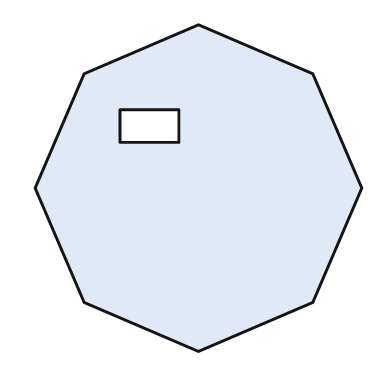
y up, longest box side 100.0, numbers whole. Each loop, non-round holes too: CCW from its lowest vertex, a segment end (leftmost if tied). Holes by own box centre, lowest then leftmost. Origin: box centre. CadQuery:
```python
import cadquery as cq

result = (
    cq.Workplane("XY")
    .moveTo(0.0, -50.0)
    .lineTo(35.0, -35.0)
    .lineTo(50.0, 0.0)
    .lineTo(35.0, 35.0)
    .lineTo(0.0, 50.0)
    .lineTo(-35.0, 35.0)
    .lineTo(-50.0, 0.0)
    .lineTo(-35.0, -35.0)
    .close()
    .moveTo(-24.0, 14.0)
    .lineTo(-6.0, 14.0)
    .lineTo(-6.0, 24.0)
    .lineTo(-24.0, 24.0)
    .close()
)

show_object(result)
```